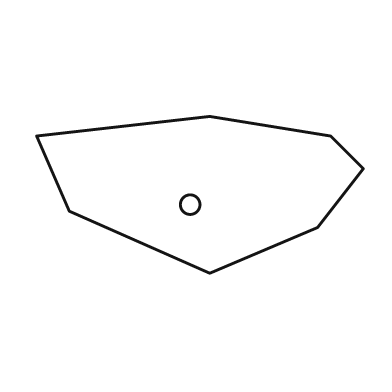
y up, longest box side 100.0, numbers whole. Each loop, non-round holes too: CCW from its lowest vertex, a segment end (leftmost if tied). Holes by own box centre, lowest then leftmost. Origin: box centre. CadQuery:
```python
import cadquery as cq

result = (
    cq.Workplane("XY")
    .moveTo(3.0, -24.0)
    .lineTo(36.0, -10.0)
    .lineTo(50.0, 8.0)
    .lineTo(40.0, 18.0)
    .lineTo(3.0, 24.0)
    .lineTo(-50.0, 18.0)
    .lineTo(-40.0, -5.0)
    .close()
    .moveTo(-3.0, -3.0)
    .circle(3.0)
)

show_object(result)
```